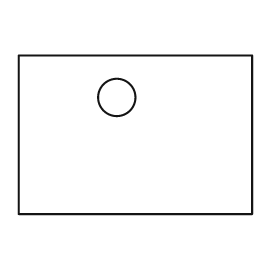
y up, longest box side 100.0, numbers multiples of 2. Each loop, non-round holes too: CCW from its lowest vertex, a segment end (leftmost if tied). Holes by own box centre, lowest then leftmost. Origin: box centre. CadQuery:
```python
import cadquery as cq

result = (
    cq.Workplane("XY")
    .moveTo(-50.0, -34.0)
    .lineTo(50.0, -34.0)
    .lineTo(50.0, 34.0)
    .lineTo(-50.0, 34.0)
    .close()
    .moveTo(-8.0, 16.0)
    .circle(8.0)
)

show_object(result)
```